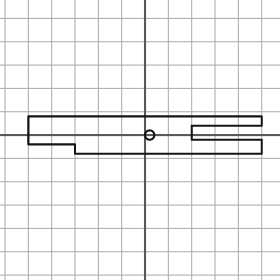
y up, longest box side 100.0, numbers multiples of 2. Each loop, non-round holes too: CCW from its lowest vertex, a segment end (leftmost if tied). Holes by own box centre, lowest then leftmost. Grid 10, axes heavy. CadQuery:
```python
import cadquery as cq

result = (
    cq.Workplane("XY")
    .moveTo(-30.0, -8.0)
    .lineTo(50.0, -8.0)
    .lineTo(50.0, -2.0)
    .lineTo(20.0, -2.0)
    .lineTo(20.0, 4.0)
    .lineTo(50.0, 4.0)
    .lineTo(50.0, 8.0)
    .lineTo(-50.0, 8.0)
    .lineTo(-50.0, -4.0)
    .lineTo(-30.0, -4.0)
    .close()
    .moveTo(2.0, 0.0)
    .circle(2.0)
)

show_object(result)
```